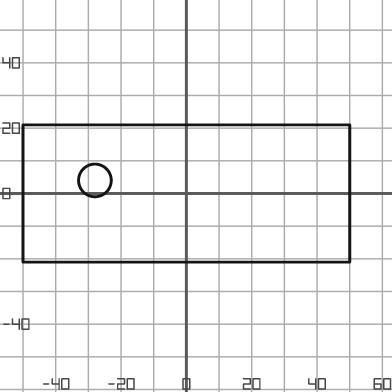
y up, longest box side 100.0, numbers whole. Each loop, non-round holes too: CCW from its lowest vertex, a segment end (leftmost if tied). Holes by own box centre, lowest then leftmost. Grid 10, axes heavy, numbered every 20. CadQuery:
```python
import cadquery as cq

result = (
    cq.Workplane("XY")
    .moveTo(-50.0, -21.0)
    .lineTo(50.0, -21.0)
    .lineTo(50.0, 21.0)
    .lineTo(-50.0, 21.0)
    .close()
    .moveTo(-28.0, 4.0)
    .circle(5.0)
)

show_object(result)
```